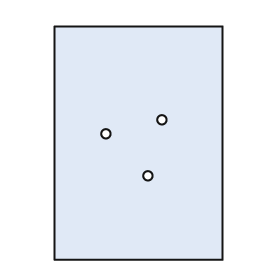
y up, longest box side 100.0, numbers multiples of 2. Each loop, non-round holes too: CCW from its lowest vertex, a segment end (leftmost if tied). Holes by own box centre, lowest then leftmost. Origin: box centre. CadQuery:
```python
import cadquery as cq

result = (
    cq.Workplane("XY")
    .moveTo(-36.0, -50.0)
    .lineTo(36.0, -50.0)
    .lineTo(36.0, 50.0)
    .lineTo(-36.0, 50.0)
    .close()
    .moveTo(4.0, -14.0)
    .circle(2.0)
    .moveTo(-14.0, 4.0)
    .circle(2.0)
    .moveTo(10.0, 10.0)
    .circle(2.0)
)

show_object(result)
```